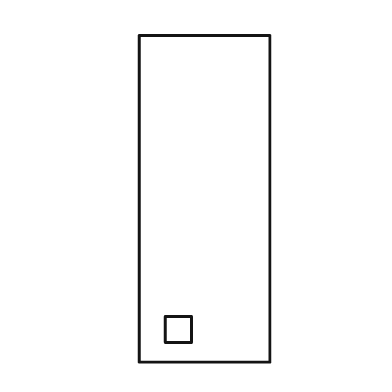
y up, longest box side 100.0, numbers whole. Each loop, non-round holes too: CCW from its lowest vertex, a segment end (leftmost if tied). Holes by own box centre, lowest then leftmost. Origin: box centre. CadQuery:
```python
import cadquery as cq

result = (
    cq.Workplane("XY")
    .moveTo(-20.0, -50.0)
    .lineTo(20.0, -50.0)
    .lineTo(20.0, 50.0)
    .lineTo(-20.0, 50.0)
    .close()
    .moveTo(-12.0, -44.0)
    .lineTo(-4.0, -44.0)
    .lineTo(-4.0, -36.0)
    .lineTo(-12.0, -36.0)
    .close()
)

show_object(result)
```